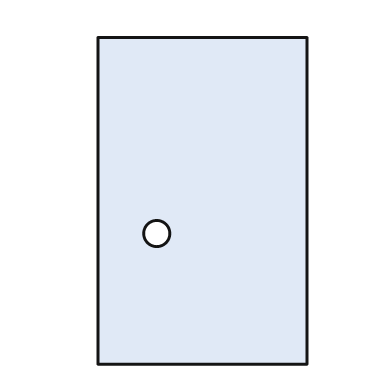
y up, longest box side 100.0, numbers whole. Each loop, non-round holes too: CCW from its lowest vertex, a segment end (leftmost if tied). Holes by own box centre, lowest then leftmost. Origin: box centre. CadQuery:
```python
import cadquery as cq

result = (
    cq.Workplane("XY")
    .moveTo(-32.0, -50.0)
    .lineTo(32.0, -50.0)
    .lineTo(32.0, 50.0)
    .lineTo(-32.0, 50.0)
    .close()
    .moveTo(-14.0, -10.0)
    .circle(4.0)
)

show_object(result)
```